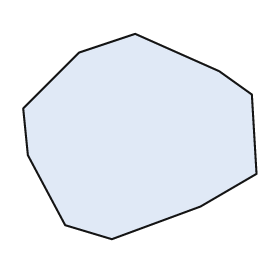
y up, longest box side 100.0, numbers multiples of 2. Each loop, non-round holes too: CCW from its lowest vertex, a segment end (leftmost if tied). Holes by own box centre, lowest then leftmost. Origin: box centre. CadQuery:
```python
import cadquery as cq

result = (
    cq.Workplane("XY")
    .moveTo(-12.0, -44.0)
    .lineTo(26.0, -30.0)
    .lineTo(50.0, -16.0)
    .lineTo(48.0, 18.0)
    .lineTo(34.0, 28.0)
    .lineTo(-2.0, 44.0)
    .lineTo(-26.0, 36.0)
    .lineTo(-50.0, 12.0)
    .lineTo(-48.0, -8.0)
    .lineTo(-32.0, -38.0)
    .close()
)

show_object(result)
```